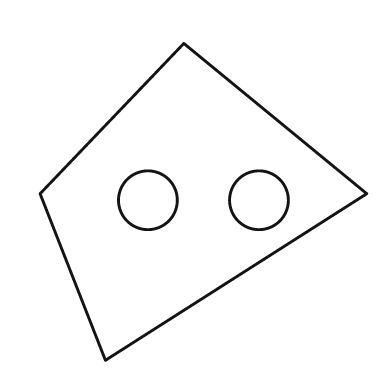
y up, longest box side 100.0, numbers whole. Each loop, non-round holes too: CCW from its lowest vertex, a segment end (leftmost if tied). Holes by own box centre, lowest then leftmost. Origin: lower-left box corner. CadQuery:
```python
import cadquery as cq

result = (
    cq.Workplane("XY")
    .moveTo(20.0, 0.0)
    .lineTo(100.0, 51.0)
    .lineTo(44.0, 97.0)
    .lineTo(0.0, 51.0)
    .close()
    .moveTo(33.0, 49.0)
    .circle(9.0)
    .moveTo(67.0, 49.0)
    .circle(9.0)
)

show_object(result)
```